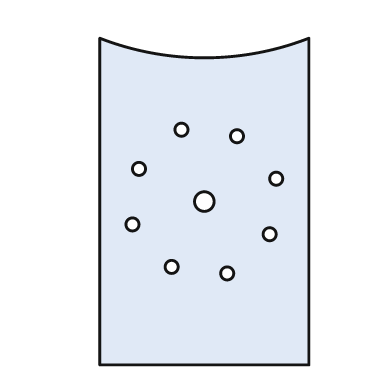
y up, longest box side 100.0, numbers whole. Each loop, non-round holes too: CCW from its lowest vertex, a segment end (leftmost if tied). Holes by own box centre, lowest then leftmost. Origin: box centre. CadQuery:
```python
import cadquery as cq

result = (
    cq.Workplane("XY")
    .moveTo(-32.0, -50.0)
    .lineTo(32.0, -50.0)
    .lineTo(32.0, 50.0)
    .threePointArc((0.0, 44.0), (-32.0, 50.0))
    .close()
    .moveTo(7.0, -22.0)
    .circle(2.0)
    .moveTo(-10.0, -20.0)
    .circle(2.0)
    .moveTo(20.0, -10.0)
    .circle(2.0)
    .moveTo(-22.0, -7.0)
    .circle(2.0)
    .moveTo(0.0, 0.0)
    .circle(3.0)
    .moveTo(22.0, 7.0)
    .circle(2.0)
    .moveTo(-20.0, 10.0)
    .circle(2.0)
    .moveTo(10.0, 20.0)
    .circle(2.0)
    .moveTo(-7.0, 22.0)
    .circle(2.0)
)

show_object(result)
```